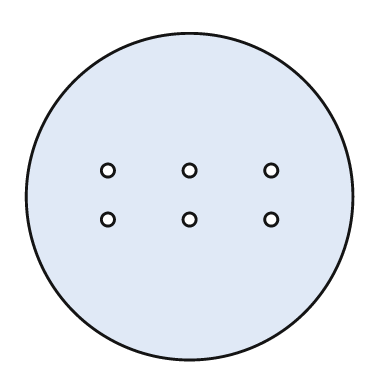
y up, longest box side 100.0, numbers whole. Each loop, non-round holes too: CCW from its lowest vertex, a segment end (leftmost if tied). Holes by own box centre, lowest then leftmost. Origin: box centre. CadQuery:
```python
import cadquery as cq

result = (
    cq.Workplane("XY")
    .moveTo(0.0, 0.0)
    .circle(50.0)
    .moveTo(-25.0, -7.0)
    .circle(2.0)
    .moveTo(0.0, -7.0)
    .circle(2.0)
    .moveTo(25.0, -7.0)
    .circle(2.0)
    .moveTo(-25.0, 8.0)
    .circle(2.0)
    .moveTo(0.0, 8.0)
    .circle(2.0)
    .moveTo(25.0, 8.0)
    .circle(2.0)
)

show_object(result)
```